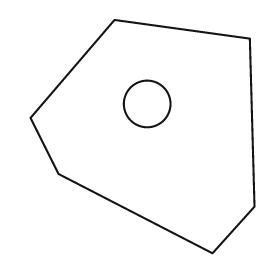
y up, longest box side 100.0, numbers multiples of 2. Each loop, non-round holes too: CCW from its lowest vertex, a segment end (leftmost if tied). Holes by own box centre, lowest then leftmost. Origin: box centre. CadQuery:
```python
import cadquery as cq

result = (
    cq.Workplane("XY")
    .moveTo(30.0, -50.0)
    .lineTo(48.0, -30.0)
    .lineTo(46.0, 42.0)
    .lineTo(-12.0, 50.0)
    .lineTo(-48.0, 8.0)
    .lineTo(-36.0, -16.0)
    .close()
    .moveTo(2.0, 14.0)
    .circle(10.0)
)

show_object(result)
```